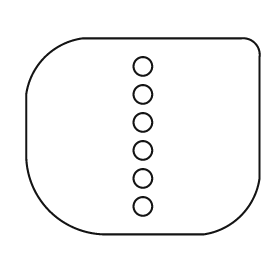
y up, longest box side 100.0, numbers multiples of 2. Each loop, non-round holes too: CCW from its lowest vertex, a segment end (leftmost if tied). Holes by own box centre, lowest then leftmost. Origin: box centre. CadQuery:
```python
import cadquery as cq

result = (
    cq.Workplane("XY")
    .moveTo(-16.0, -42.0)
    .lineTo(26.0, -42.0)
    .threePointArc((42.0, -34.0), (50.0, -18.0))
    .lineTo(50.0, 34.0)
    .threePointArc((48.0, 40.0), (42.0, 42.0))
    .lineTo(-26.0, 42.0)
    .threePointArc((-42.0, 34.0), (-50.0, 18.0))
    .lineTo(-50.0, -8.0)
    .threePointArc((-40.0, -32.0), (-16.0, -42.0))
    .close()
    .moveTo(0.0, -30.0)
    .circle(4.0)
    .moveTo(0.0, -18.0)
    .circle(4.0)
    .moveTo(0.0, -6.0)
    .circle(4.0)
    .moveTo(0.0, 6.0)
    .circle(4.0)
    .moveTo(0.0, 18.0)
    .circle(4.0)
    .moveTo(0.0, 30.0)
    .circle(4.0)
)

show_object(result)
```